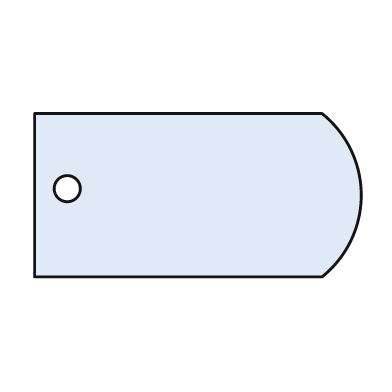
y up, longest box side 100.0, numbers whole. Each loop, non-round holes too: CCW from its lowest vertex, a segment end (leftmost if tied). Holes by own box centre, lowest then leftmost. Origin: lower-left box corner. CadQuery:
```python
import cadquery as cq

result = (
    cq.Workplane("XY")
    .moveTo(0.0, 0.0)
    .lineTo(88.0, 0.0)
    .threePointArc((100.0, 25.0), (88.0, 50.0))
    .lineTo(0.0, 50.0)
    .close()
    .moveTo(10.0, 27.0)
    .circle(4.0)
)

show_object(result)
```